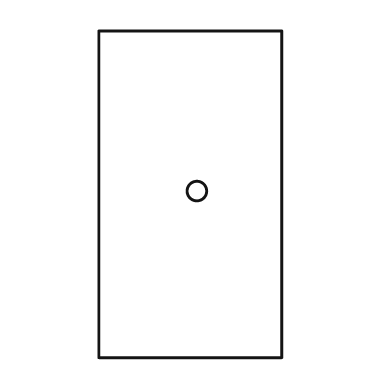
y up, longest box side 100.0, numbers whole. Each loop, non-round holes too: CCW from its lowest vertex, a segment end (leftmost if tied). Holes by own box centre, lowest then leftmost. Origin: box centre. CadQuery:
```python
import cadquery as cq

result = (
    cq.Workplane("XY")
    .moveTo(-28.0, -50.0)
    .lineTo(28.0, -50.0)
    .lineTo(28.0, 50.0)
    .lineTo(-28.0, 50.0)
    .close()
    .moveTo(2.0, 1.0)
    .circle(3.0)
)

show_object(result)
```